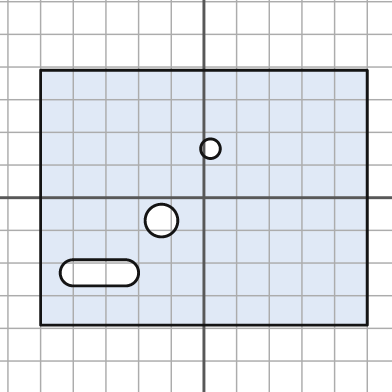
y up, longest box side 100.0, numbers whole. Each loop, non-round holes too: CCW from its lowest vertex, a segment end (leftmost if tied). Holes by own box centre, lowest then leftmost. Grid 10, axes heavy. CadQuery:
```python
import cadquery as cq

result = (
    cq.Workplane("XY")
    .moveTo(-50.0, -39.0)
    .lineTo(50.0, -39.0)
    .lineTo(50.0, 39.0)
    .lineTo(-50.0, 39.0)
    .close()
    .moveTo(-40.0, -27.0)
    .lineTo(-24.0, -27.0)
    .threePointArc((-20.0, -23.0), (-24.0, -19.0))
    .lineTo(-40.0, -19.0)
    .threePointArc((-44.0, -23.0), (-40.0, -27.0))
    .close()
    .moveTo(-13.0, -7.0)
    .circle(5.0)
    .moveTo(2.0, 15.0)
    .circle(3.0)
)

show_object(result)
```